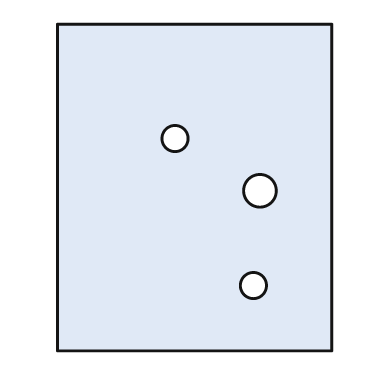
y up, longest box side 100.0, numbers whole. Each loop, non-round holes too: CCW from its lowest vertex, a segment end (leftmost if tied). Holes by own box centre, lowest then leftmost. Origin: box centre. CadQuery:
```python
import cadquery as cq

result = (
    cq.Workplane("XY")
    .moveTo(-42.0, -50.0)
    .lineTo(42.0, -50.0)
    .lineTo(42.0, 50.0)
    .lineTo(-42.0, 50.0)
    .close()
    .moveTo(18.0, -30.0)
    .circle(4.0)
    .moveTo(20.0, -1.0)
    .circle(5.0)
    .moveTo(-6.0, 15.0)
    .circle(4.0)
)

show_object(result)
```